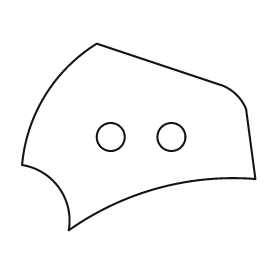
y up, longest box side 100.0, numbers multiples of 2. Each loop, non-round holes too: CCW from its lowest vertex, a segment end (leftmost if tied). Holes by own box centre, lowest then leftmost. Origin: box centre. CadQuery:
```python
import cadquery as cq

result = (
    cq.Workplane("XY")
    .moveTo(-30.0, -40.0)
    .threePointArc((8.0, -22.0), (50.0, -18.0))
    .lineTo(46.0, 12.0)
    .threePointArc((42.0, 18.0), (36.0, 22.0))
    .lineTo(-18.0, 40.0)
    .threePointArc((-40.0, 18.0), (-50.0, -12.0))
    .threePointArc((-34.0, -22.0), (-30.0, -40.0))
    .close()
    .moveTo(-12.0, 0.0)
    .circle(6.0)
    .moveTo(14.0, 0.0)
    .circle(6.0)
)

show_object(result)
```